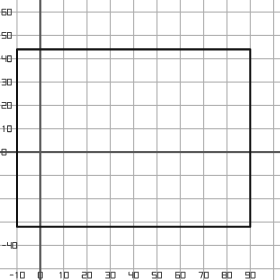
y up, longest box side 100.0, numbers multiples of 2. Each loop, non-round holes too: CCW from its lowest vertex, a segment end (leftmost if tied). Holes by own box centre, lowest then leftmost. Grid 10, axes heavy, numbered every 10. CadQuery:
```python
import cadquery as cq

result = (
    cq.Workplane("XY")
    .moveTo(-10.0, -32.0)
    .lineTo(90.0, -32.0)
    .lineTo(90.0, 44.0)
    .lineTo(-10.0, 44.0)
    .close()
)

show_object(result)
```